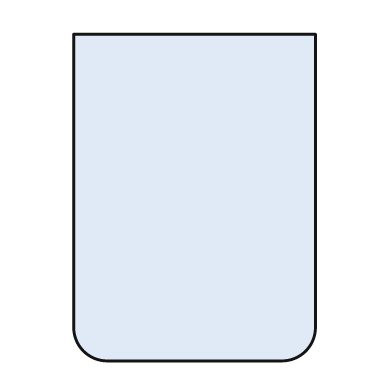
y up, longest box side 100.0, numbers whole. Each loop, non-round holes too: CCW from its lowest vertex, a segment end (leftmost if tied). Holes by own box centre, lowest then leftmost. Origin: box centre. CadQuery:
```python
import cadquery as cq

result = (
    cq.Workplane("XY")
    .moveTo(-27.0, -50.0)
    .lineTo(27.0, -50.0)
    .threePointArc((34.0, -47.0), (37.0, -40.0))
    .lineTo(37.0, 50.0)
    .lineTo(-37.0, 50.0)
    .lineTo(-37.0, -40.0)
    .threePointArc((-34.0, -47.0), (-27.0, -50.0))
    .close()
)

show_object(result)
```